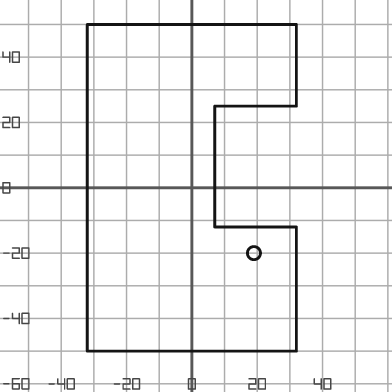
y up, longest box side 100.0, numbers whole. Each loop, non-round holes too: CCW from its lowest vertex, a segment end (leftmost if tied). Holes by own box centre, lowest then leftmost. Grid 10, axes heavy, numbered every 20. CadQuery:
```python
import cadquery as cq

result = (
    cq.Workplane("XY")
    .moveTo(-32.0, -50.0)
    .lineTo(32.0, -50.0)
    .lineTo(32.0, -12.0)
    .lineTo(7.0, -12.0)
    .lineTo(7.0, 25.0)
    .lineTo(32.0, 25.0)
    .lineTo(32.0, 50.0)
    .lineTo(-32.0, 50.0)
    .close()
    .moveTo(19.0, -20.0)
    .circle(2.0)
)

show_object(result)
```